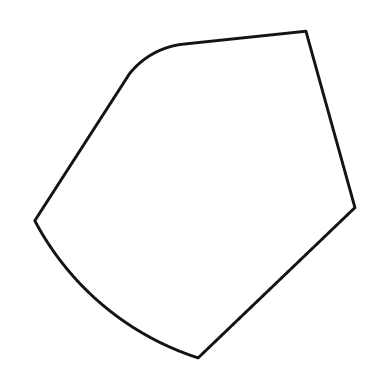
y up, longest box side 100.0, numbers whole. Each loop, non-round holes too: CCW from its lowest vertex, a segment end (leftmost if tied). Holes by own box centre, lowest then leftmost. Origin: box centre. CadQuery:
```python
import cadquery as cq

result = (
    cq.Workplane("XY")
    .moveTo(1.0, -50.0)
    .lineTo(49.0, -4.0)
    .lineTo(34.0, 50.0)
    .lineTo(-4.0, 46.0)
    .threePointArc((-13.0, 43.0), (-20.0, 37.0))
    .lineTo(-49.0, -8.0)
    .threePointArc((-28.0, -34.0), (1.0, -50.0))
    .close()
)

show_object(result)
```